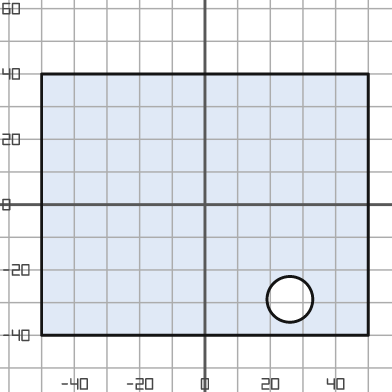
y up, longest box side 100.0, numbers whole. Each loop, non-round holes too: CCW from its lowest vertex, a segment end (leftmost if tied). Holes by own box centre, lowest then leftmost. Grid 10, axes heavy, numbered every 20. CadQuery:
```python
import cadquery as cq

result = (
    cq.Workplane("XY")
    .moveTo(-50.0, -40.0)
    .lineTo(50.0, -40.0)
    .lineTo(50.0, 40.0)
    .lineTo(-50.0, 40.0)
    .close()
    .moveTo(26.0, -29.0)
    .circle(7.0)
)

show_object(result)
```